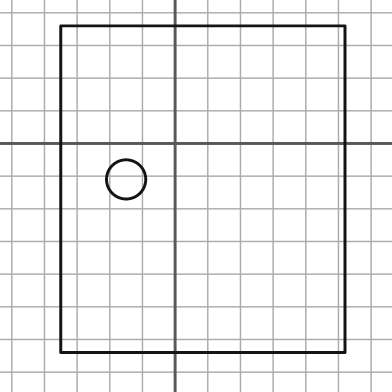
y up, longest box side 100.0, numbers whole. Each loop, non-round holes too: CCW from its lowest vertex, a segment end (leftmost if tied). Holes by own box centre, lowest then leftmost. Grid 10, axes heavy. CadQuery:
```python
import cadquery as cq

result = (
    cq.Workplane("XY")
    .moveTo(-35.0, -64.0)
    .lineTo(52.0, -64.0)
    .lineTo(52.0, 36.0)
    .lineTo(-35.0, 36.0)
    .close()
    .moveTo(-15.0, -11.0)
    .circle(6.0)
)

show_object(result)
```